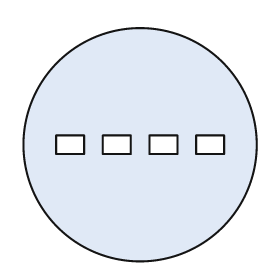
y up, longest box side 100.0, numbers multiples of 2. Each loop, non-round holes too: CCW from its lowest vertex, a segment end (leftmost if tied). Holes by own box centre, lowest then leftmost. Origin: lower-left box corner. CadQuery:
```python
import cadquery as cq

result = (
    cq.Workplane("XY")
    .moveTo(50.0, 50.0)
    .circle(50.0)
    .moveTo(14.0, 46.0)
    .lineTo(26.0, 46.0)
    .lineTo(26.0, 54.0)
    .lineTo(14.0, 54.0)
    .close()
    .moveTo(34.0, 46.0)
    .lineTo(46.0, 46.0)
    .lineTo(46.0, 54.0)
    .lineTo(34.0, 54.0)
    .close()
    .moveTo(54.0, 46.0)
    .lineTo(66.0, 46.0)
    .lineTo(66.0, 54.0)
    .lineTo(54.0, 54.0)
    .close()
    .moveTo(74.0, 46.0)
    .lineTo(86.0, 46.0)
    .lineTo(86.0, 54.0)
    .lineTo(74.0, 54.0)
    .close()
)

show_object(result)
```